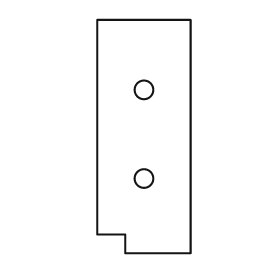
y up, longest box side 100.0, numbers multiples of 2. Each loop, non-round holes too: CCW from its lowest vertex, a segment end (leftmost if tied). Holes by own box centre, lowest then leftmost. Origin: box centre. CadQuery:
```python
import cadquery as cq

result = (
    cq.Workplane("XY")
    .moveTo(-8.0, -50.0)
    .lineTo(20.0, -50.0)
    .lineTo(20.0, 50.0)
    .lineTo(-20.0, 50.0)
    .lineTo(-20.0, -42.0)
    .lineTo(-8.0, -42.0)
    .close()
    .moveTo(0.0, -18.0)
    .circle(4.0)
    .moveTo(0.0, 20.0)
    .circle(4.0)
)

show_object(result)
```